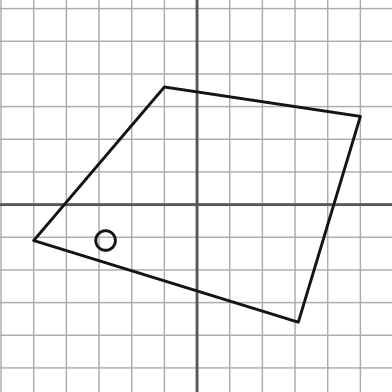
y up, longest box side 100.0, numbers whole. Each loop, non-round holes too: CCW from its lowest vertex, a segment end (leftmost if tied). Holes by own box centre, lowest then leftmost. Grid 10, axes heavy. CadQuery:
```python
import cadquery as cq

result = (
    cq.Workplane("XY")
    .moveTo(31.0, -36.0)
    .lineTo(50.0, 27.0)
    .lineTo(-10.0, 36.0)
    .lineTo(-50.0, -11.0)
    .close()
    .moveTo(-28.0, -11.0)
    .circle(3.0)
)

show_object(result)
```